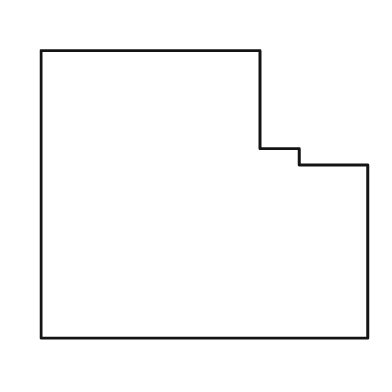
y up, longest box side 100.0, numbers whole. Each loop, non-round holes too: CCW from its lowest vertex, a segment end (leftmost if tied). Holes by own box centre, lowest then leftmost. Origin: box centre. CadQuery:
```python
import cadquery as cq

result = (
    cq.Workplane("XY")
    .moveTo(-50.0, -44.0)
    .lineTo(50.0, -44.0)
    .lineTo(50.0, 9.0)
    .lineTo(29.0, 9.0)
    .lineTo(29.0, 14.0)
    .lineTo(17.0, 14.0)
    .lineTo(17.0, 44.0)
    .lineTo(-50.0, 44.0)
    .close()
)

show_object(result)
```